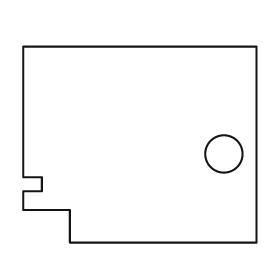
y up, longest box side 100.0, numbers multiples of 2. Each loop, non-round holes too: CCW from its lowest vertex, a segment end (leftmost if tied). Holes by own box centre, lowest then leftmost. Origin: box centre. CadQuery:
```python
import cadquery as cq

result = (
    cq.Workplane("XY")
    .moveTo(-30.0, -42.0)
    .lineTo(50.0, -42.0)
    .lineTo(50.0, 42.0)
    .lineTo(-50.0, 42.0)
    .lineTo(-50.0, -14.0)
    .lineTo(-42.0, -14.0)
    .lineTo(-42.0, -20.0)
    .lineTo(-50.0, -20.0)
    .lineTo(-50.0, -28.0)
    .lineTo(-30.0, -28.0)
    .close()
    .moveTo(36.0, -4.0)
    .circle(8.0)
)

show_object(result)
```